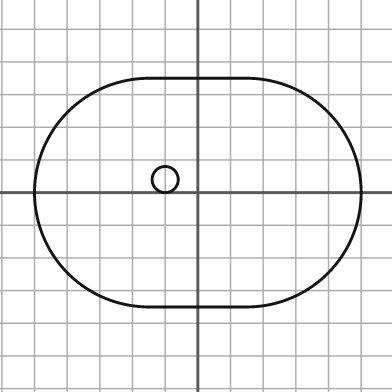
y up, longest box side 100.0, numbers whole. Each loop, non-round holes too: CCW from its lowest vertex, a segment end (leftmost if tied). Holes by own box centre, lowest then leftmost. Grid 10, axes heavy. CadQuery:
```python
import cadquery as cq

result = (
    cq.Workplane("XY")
    .moveTo(-15.0, -35.0)
    .lineTo(15.0, -35.0)
    .threePointArc((50.0, 0.0), (15.0, 35.0))
    .lineTo(-15.0, 35.0)
    .threePointArc((-50.0, 0.0), (-15.0, -35.0))
    .close()
    .moveTo(-10.0, 4.0)
    .circle(4.0)
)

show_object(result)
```